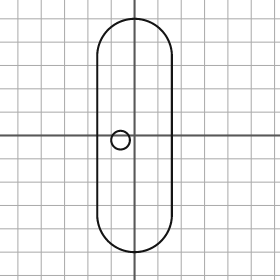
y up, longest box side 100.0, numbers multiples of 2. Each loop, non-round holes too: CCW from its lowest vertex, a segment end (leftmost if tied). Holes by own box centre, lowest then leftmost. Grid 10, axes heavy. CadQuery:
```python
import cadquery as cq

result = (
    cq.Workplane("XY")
    .moveTo(-16.0, -34.0)
    .threePointArc((0.0, -50.0), (16.0, -34.0))
    .lineTo(16.0, 34.0)
    .threePointArc((0.0, 50.0), (-16.0, 34.0))
    .close()
    .moveTo(-6.0, -2.0)
    .circle(4.0)
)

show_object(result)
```